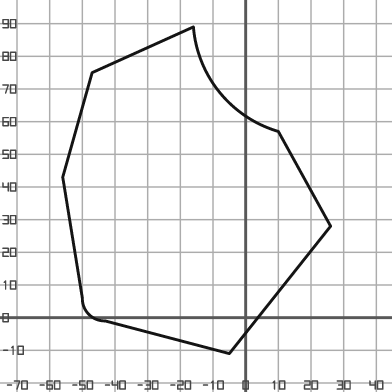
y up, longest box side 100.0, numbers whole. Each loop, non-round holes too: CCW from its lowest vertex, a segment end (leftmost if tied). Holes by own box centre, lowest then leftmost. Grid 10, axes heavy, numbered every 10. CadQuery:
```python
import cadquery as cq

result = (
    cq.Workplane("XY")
    .moveTo(-5.0, -11.0)
    .lineTo(26.0, 28.0)
    .lineTo(10.0, 57.0)
    .threePointArc((-8.0, 69.0), (-16.0, 89.0))
    .lineTo(-47.0, 75.0)
    .lineTo(-56.0, 43.0)
    .lineTo(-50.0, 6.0)
    .threePointArc((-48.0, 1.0), (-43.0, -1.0))
    .close()
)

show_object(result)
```